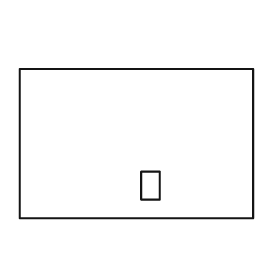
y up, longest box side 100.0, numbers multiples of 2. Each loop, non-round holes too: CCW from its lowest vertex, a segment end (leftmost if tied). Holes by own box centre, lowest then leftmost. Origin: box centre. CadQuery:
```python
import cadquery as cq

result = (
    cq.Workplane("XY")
    .moveTo(-50.0, -32.0)
    .lineTo(50.0, -32.0)
    .lineTo(50.0, 32.0)
    .lineTo(-50.0, 32.0)
    .close()
    .moveTo(2.0, -24.0)
    .lineTo(10.0, -24.0)
    .lineTo(10.0, -12.0)
    .lineTo(2.0, -12.0)
    .close()
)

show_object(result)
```